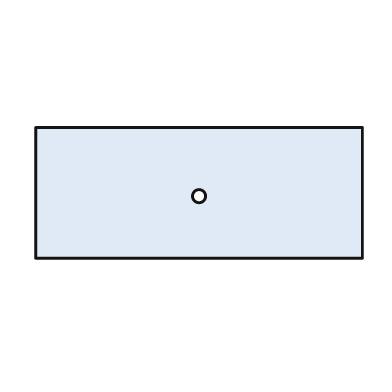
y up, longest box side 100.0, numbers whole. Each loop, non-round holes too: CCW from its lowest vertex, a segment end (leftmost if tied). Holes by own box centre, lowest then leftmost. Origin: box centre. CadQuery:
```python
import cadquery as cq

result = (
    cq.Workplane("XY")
    .moveTo(-50.0, -20.0)
    .lineTo(50.0, -20.0)
    .lineTo(50.0, 20.0)
    .lineTo(-50.0, 20.0)
    .close()
    .moveTo(0.0, -1.0)
    .circle(2.0)
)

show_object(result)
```